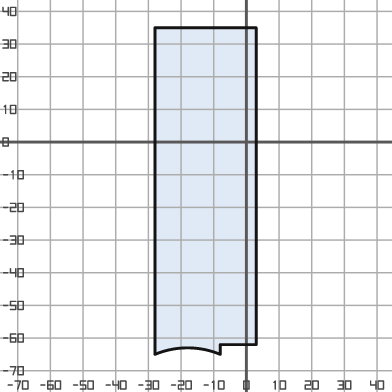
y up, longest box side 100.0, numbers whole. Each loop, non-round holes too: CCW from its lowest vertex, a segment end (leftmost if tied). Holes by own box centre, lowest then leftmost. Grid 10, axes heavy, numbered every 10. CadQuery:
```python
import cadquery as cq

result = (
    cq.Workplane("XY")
    .moveTo(-28.0, -65.0)
    .threePointArc((-18.0, -63.0), (-8.0, -65.0))
    .lineTo(-8.0, -62.0)
    .lineTo(3.0, -62.0)
    .lineTo(3.0, 35.0)
    .lineTo(-28.0, 35.0)
    .close()
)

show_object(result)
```